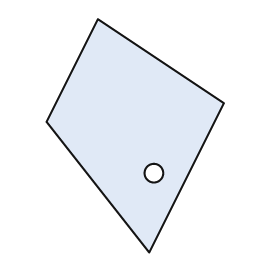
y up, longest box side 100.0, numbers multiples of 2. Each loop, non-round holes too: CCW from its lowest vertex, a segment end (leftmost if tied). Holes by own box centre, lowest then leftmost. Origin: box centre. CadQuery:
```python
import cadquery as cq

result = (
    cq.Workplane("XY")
    .moveTo(6.0, -50.0)
    .lineTo(38.0, 14.0)
    .lineTo(-16.0, 50.0)
    .lineTo(-38.0, 6.0)
    .close()
    .moveTo(8.0, -16.0)
    .circle(4.0)
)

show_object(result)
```